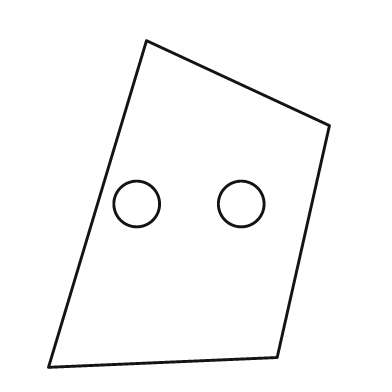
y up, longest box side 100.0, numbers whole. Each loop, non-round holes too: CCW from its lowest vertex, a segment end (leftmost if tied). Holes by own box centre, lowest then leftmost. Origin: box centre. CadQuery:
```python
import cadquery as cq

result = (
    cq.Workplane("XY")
    .moveTo(-43.0, -50.0)
    .lineTo(27.0, -47.0)
    .lineTo(43.0, 24.0)
    .lineTo(-13.0, 50.0)
    .close()
    .moveTo(-16.0, 0.0)
    .circle(7.0)
    .moveTo(16.0, 0.0)
    .circle(7.0)
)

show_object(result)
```